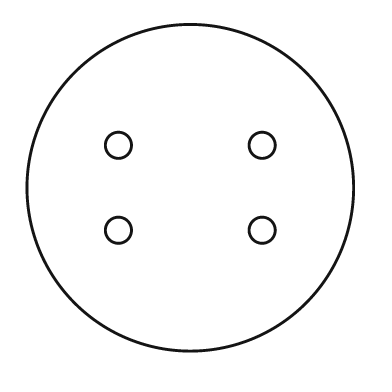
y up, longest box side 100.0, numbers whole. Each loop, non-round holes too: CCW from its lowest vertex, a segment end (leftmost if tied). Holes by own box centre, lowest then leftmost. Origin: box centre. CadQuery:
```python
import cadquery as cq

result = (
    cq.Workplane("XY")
    .moveTo(0.0, 0.0)
    .circle(50.0)
    .moveTo(-22.0, -13.0)
    .circle(4.0)
    .moveTo(22.0, -13.0)
    .circle(4.0)
    .moveTo(-22.0, 13.0)
    .circle(4.0)
    .moveTo(22.0, 13.0)
    .circle(4.0)
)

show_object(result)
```